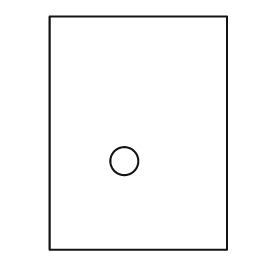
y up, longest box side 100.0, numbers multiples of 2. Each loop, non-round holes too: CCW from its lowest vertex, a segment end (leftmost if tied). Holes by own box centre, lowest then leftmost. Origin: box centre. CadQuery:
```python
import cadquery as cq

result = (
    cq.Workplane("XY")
    .moveTo(-38.0, -50.0)
    .lineTo(38.0, -50.0)
    .lineTo(38.0, 50.0)
    .lineTo(-38.0, 50.0)
    .close()
    .moveTo(-6.0, -12.0)
    .circle(6.0)
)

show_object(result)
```